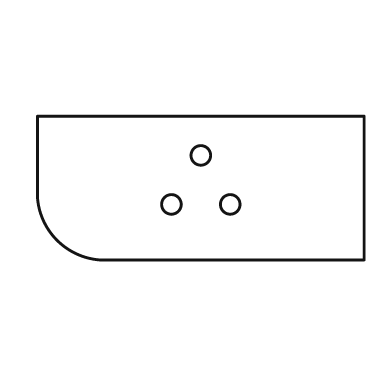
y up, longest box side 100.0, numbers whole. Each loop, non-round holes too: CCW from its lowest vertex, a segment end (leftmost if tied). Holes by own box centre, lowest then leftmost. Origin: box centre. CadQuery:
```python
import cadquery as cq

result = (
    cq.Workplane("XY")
    .moveTo(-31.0, -22.0)
    .lineTo(50.0, -22.0)
    .lineTo(50.0, 22.0)
    .lineTo(-50.0, 22.0)
    .lineTo(-50.0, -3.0)
    .threePointArc((-44.0, -16.0), (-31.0, -22.0))
    .close()
    .moveTo(-9.0, -5.0)
    .circle(3.0)
    .moveTo(9.0, -5.0)
    .circle(3.0)
    .moveTo(0.0, 10.0)
    .circle(3.0)
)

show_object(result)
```